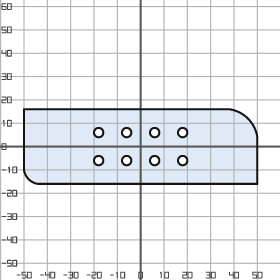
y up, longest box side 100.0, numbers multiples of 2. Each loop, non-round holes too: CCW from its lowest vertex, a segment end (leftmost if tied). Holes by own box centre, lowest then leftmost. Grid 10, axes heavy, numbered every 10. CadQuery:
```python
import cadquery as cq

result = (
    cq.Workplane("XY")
    .moveTo(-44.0, -16.0)
    .lineTo(50.0, -16.0)
    .lineTo(50.0, 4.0)
    .threePointArc((46.0, 12.0), (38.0, 16.0))
    .lineTo(-50.0, 16.0)
    .lineTo(-50.0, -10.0)
    .threePointArc((-48.0, -14.0), (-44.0, -16.0))
    .close()
    .moveTo(-18.0, -6.0)
    .circle(2.0)
    .moveTo(-6.0, -6.0)
    .circle(2.0)
    .moveTo(6.0, -6.0)
    .circle(2.0)
    .moveTo(18.0, -6.0)
    .circle(2.0)
    .moveTo(-18.0, 6.0)
    .circle(2.0)
    .moveTo(-6.0, 6.0)
    .circle(2.0)
    .moveTo(6.0, 6.0)
    .circle(2.0)
    .moveTo(18.0, 6.0)
    .circle(2.0)
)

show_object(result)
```